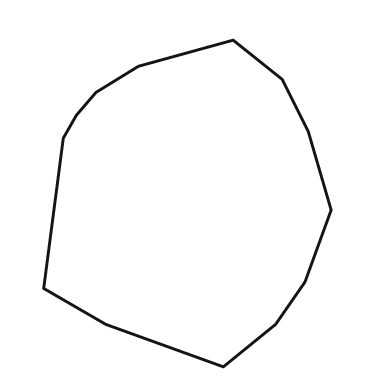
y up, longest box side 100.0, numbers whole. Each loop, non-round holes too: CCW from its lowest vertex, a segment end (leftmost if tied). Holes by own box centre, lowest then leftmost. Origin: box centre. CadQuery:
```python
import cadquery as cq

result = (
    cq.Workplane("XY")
    .moveTo(11.0, -50.0)
    .lineTo(27.0, -37.0)
    .lineTo(36.0, -24.0)
    .lineTo(44.0, -2.0)
    .lineTo(37.0, 22.0)
    .lineTo(29.0, 38.0)
    .lineTo(14.0, 50.0)
    .lineTo(-15.0, 42.0)
    .lineTo(-28.0, 34.0)
    .lineTo(-34.0, 27.0)
    .lineTo(-38.0, 20.0)
    .lineTo(-44.0, -26.0)
    .lineTo(-25.0, -37.0)
    .close()
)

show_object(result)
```